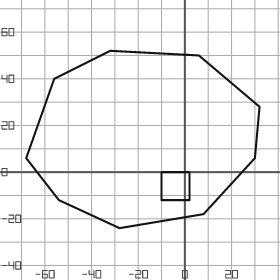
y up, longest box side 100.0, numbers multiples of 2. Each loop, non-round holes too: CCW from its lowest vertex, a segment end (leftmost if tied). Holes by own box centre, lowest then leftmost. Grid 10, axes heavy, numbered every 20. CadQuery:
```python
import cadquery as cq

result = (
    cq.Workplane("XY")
    .moveTo(-28.0, -24.0)
    .lineTo(8.0, -18.0)
    .lineTo(30.0, 6.0)
    .lineTo(32.0, 28.0)
    .lineTo(6.0, 50.0)
    .lineTo(-32.0, 52.0)
    .lineTo(-56.0, 40.0)
    .lineTo(-68.0, 6.0)
    .lineTo(-54.0, -12.0)
    .close()
    .moveTo(-10.0, -12.0)
    .lineTo(2.0, -12.0)
    .lineTo(2.0, 0.0)
    .lineTo(-10.0, 0.0)
    .close()
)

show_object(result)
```